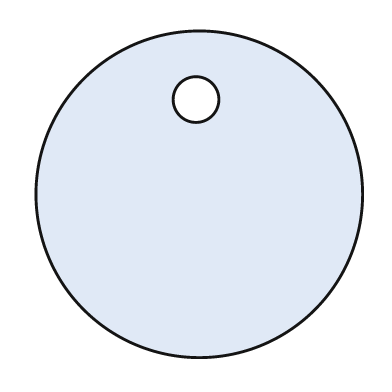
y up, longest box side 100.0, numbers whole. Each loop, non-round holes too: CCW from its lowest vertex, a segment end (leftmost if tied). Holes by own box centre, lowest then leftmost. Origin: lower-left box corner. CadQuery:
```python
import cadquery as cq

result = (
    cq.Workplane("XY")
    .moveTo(50.0, 50.0)
    .circle(50.0)
    .moveTo(49.0, 79.0)
    .circle(7.0)
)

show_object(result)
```